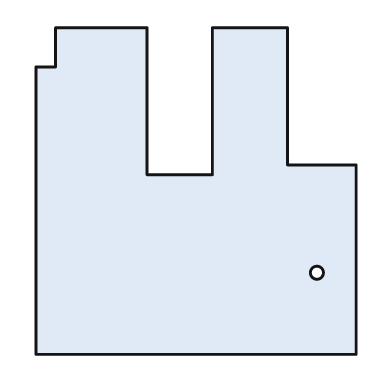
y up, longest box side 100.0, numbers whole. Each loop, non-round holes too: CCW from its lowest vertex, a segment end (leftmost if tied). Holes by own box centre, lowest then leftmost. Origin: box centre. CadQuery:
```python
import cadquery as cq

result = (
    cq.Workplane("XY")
    .moveTo(-49.0, -50.0)
    .lineTo(49.0, -50.0)
    .lineTo(49.0, 8.0)
    .lineTo(28.0, 8.0)
    .lineTo(28.0, 50.0)
    .lineTo(5.0, 50.0)
    .lineTo(5.0, 5.0)
    .lineTo(-15.0, 5.0)
    .lineTo(-15.0, 50.0)
    .lineTo(-43.0, 50.0)
    .lineTo(-43.0, 38.0)
    .lineTo(-49.0, 38.0)
    .close()
    .moveTo(37.0, -25.0)
    .circle(2.0)
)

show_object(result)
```